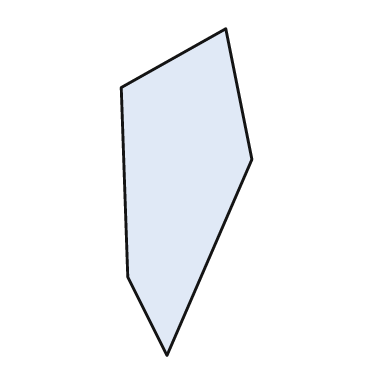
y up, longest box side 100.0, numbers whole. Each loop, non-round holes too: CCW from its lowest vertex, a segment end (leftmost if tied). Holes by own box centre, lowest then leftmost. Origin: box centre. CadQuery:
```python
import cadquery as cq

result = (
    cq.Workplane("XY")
    .moveTo(-6.0, -50.0)
    .lineTo(20.0, 10.0)
    .lineTo(12.0, 50.0)
    .lineTo(-20.0, 32.0)
    .lineTo(-18.0, -26.0)
    .close()
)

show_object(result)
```